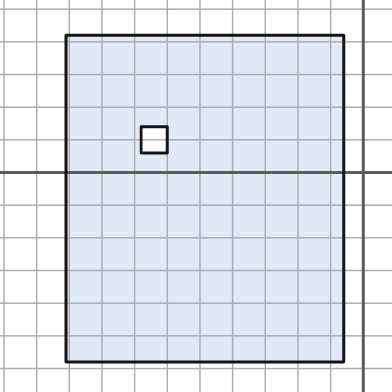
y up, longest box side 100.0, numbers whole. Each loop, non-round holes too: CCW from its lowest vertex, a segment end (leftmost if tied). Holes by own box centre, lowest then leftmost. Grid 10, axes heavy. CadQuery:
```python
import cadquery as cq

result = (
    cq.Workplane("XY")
    .moveTo(-91.0, -58.0)
    .lineTo(-6.0, -58.0)
    .lineTo(-6.0, 42.0)
    .lineTo(-91.0, 42.0)
    .close()
    .moveTo(-68.0, 6.0)
    .lineTo(-60.0, 6.0)
    .lineTo(-60.0, 14.0)
    .lineTo(-68.0, 14.0)
    .close()
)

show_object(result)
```